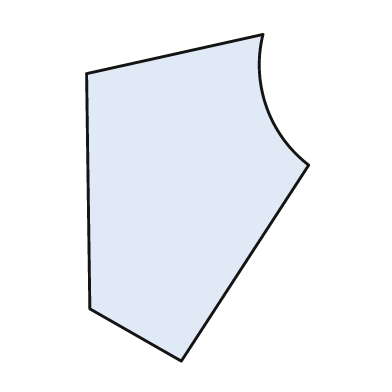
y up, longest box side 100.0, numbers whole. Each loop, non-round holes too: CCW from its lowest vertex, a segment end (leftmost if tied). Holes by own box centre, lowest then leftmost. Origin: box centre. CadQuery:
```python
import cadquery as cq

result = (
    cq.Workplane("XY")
    .moveTo(-5.0, -50.0)
    .lineTo(34.0, 10.0)
    .threePointArc((21.0, 28.0), (20.0, 50.0))
    .lineTo(-34.0, 38.0)
    .lineTo(-33.0, -34.0)
    .close()
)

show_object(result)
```